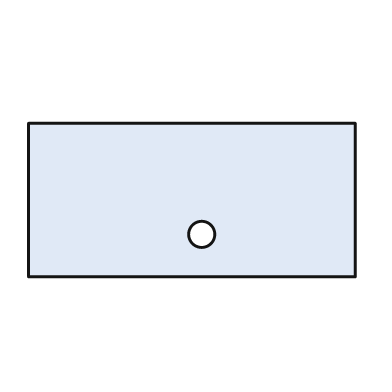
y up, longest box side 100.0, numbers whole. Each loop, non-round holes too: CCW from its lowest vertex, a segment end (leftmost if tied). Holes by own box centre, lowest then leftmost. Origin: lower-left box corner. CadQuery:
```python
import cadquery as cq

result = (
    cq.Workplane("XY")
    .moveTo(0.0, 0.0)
    .lineTo(100.0, 0.0)
    .lineTo(100.0, 47.0)
    .lineTo(0.0, 47.0)
    .close()
    .moveTo(53.0, 13.0)
    .circle(4.0)
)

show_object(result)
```